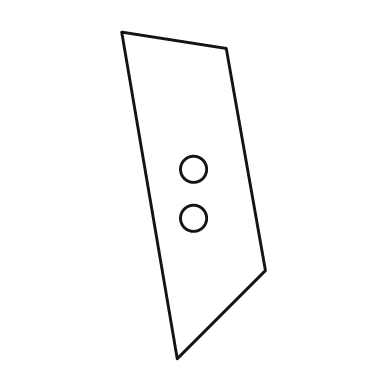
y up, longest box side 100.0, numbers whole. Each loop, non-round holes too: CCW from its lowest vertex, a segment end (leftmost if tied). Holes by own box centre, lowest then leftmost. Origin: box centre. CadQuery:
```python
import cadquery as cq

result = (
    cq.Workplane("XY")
    .moveTo(-5.0, -50.0)
    .lineTo(22.0, -23.0)
    .lineTo(10.0, 45.0)
    .lineTo(-22.0, 50.0)
    .close()
    .moveTo(0.0, -7.0)
    .circle(4.0)
    .moveTo(0.0, 8.0)
    .circle(4.0)
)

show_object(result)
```